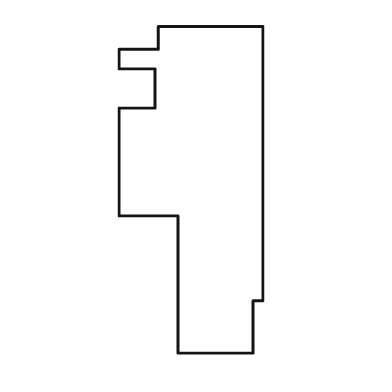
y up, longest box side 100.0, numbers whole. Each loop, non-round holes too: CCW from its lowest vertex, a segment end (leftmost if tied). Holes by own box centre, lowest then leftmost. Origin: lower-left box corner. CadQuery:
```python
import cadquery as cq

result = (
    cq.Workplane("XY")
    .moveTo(18.0, 0.0)
    .lineTo(41.0, 0.0)
    .lineTo(41.0, 16.0)
    .lineTo(44.0, 16.0)
    .lineTo(44.0, 100.0)
    .lineTo(12.0, 100.0)
    .lineTo(12.0, 93.0)
    .lineTo(0.0, 93.0)
    .lineTo(0.0, 87.0)
    .lineTo(11.0, 87.0)
    .lineTo(11.0, 75.0)
    .lineTo(0.0, 75.0)
    .lineTo(0.0, 42.0)
    .lineTo(18.0, 42.0)
    .close()
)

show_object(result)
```